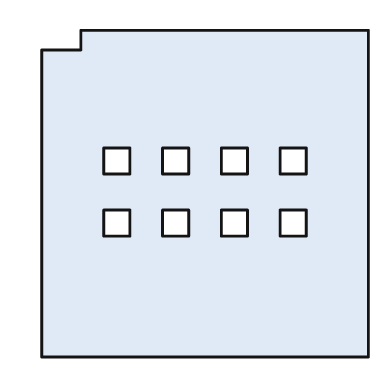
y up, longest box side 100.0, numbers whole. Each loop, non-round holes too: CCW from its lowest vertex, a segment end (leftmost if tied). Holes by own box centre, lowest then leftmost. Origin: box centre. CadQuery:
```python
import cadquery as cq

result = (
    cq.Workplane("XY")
    .moveTo(-50.0, -50.0)
    .lineTo(50.0, -50.0)
    .lineTo(50.0, 50.0)
    .lineTo(-38.0, 50.0)
    .lineTo(-38.0, 44.0)
    .lineTo(-50.0, 44.0)
    .close()
    .moveTo(-31.0, -13.0)
    .lineTo(-23.0, -13.0)
    .lineTo(-23.0, -5.0)
    .lineTo(-31.0, -5.0)
    .close()
    .moveTo(-13.0, -13.0)
    .lineTo(-5.0, -13.0)
    .lineTo(-5.0, -5.0)
    .lineTo(-13.0, -5.0)
    .close()
    .moveTo(5.0, -13.0)
    .lineTo(13.0, -13.0)
    .lineTo(13.0, -5.0)
    .lineTo(5.0, -5.0)
    .close()
    .moveTo(23.0, -13.0)
    .lineTo(31.0, -13.0)
    .lineTo(31.0, -5.0)
    .lineTo(23.0, -5.0)
    .close()
    .moveTo(-31.0, 6.0)
    .lineTo(-23.0, 6.0)
    .lineTo(-23.0, 14.0)
    .lineTo(-31.0, 14.0)
    .close()
    .moveTo(-13.0, 6.0)
    .lineTo(-5.0, 6.0)
    .lineTo(-5.0, 14.0)
    .lineTo(-13.0, 14.0)
    .close()
    .moveTo(5.0, 6.0)
    .lineTo(13.0, 6.0)
    .lineTo(13.0, 14.0)
    .lineTo(5.0, 14.0)
    .close()
    .moveTo(23.0, 6.0)
    .lineTo(31.0, 6.0)
    .lineTo(31.0, 14.0)
    .lineTo(23.0, 14.0)
    .close()
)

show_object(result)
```